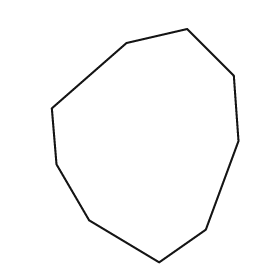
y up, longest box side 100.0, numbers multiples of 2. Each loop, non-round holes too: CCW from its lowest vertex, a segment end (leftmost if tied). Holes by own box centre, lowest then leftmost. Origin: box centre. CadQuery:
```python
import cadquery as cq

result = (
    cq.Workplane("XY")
    .moveTo(6.0, -50.0)
    .lineTo(26.0, -36.0)
    .lineTo(40.0, 2.0)
    .lineTo(38.0, 30.0)
    .lineTo(18.0, 50.0)
    .lineTo(-8.0, 44.0)
    .lineTo(-40.0, 16.0)
    .lineTo(-38.0, -8.0)
    .lineTo(-24.0, -32.0)
    .close()
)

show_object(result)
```